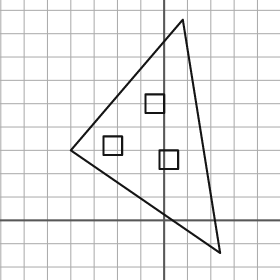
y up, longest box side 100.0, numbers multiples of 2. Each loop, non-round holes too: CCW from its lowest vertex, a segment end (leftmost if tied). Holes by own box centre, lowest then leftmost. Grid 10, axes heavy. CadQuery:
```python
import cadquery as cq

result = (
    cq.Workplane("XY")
    .moveTo(24.0, -14.0)
    .lineTo(8.0, 86.0)
    .lineTo(-40.0, 30.0)
    .close()
    .moveTo(-2.0, 22.0)
    .lineTo(6.0, 22.0)
    .lineTo(6.0, 30.0)
    .lineTo(-2.0, 30.0)
    .close()
    .moveTo(-26.0, 28.0)
    .lineTo(-18.0, 28.0)
    .lineTo(-18.0, 36.0)
    .lineTo(-26.0, 36.0)
    .close()
    .moveTo(-8.0, 46.0)
    .lineTo(0.0, 46.0)
    .lineTo(0.0, 54.0)
    .lineTo(-8.0, 54.0)
    .close()
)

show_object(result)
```